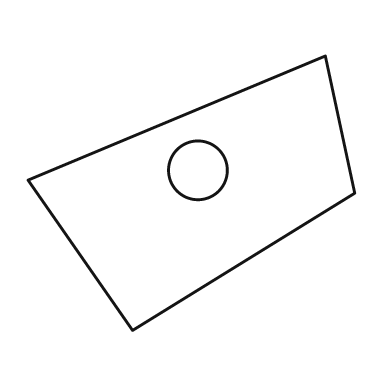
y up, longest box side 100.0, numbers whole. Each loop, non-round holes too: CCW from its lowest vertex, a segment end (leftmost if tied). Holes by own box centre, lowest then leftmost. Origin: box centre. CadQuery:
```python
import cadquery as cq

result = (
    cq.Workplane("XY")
    .moveTo(-18.0, -42.0)
    .lineTo(50.0, 0.0)
    .lineTo(41.0, 42.0)
    .lineTo(-50.0, 4.0)
    .close()
    .moveTo(2.0, 7.0)
    .circle(9.0)
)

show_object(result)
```